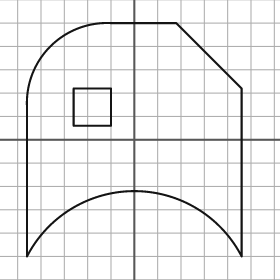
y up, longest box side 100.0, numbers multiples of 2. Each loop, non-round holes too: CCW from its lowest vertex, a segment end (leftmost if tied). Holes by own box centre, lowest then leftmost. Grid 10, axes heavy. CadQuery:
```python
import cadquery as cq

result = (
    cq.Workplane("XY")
    .moveTo(-46.0, -50.0)
    .threePointArc((0.0, -22.0), (46.0, -50.0))
    .lineTo(46.0, 22.0)
    .lineTo(18.0, 50.0)
    .lineTo(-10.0, 50.0)
    .threePointArc((-36.0, 40.0), (-46.0, 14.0))
    .close()
    .moveTo(-26.0, 6.0)
    .lineTo(-10.0, 6.0)
    .lineTo(-10.0, 22.0)
    .lineTo(-26.0, 22.0)
    .close()
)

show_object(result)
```